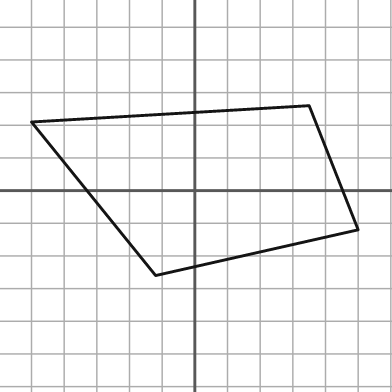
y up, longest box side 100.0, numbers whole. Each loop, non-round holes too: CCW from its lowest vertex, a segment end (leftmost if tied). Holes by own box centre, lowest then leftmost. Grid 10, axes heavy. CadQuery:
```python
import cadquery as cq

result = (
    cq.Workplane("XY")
    .moveTo(-12.0, -26.0)
    .lineTo(50.0, -12.0)
    .lineTo(35.0, 26.0)
    .lineTo(-50.0, 21.0)
    .close()
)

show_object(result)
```